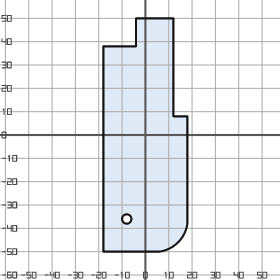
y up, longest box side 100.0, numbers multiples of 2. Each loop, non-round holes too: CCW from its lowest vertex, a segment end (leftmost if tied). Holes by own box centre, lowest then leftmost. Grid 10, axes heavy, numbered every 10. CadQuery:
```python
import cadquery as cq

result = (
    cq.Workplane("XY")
    .moveTo(-18.0, -50.0)
    .lineTo(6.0, -50.0)
    .threePointArc((14.0, -46.0), (18.0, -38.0))
    .lineTo(18.0, 8.0)
    .lineTo(12.0, 8.0)
    .lineTo(12.0, 50.0)
    .lineTo(-4.0, 50.0)
    .lineTo(-4.0, 38.0)
    .lineTo(-18.0, 38.0)
    .close()
    .moveTo(-8.0, -36.0)
    .circle(2.0)
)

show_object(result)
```